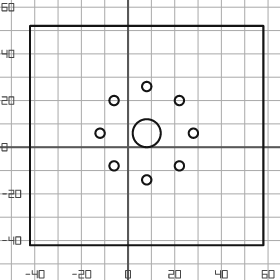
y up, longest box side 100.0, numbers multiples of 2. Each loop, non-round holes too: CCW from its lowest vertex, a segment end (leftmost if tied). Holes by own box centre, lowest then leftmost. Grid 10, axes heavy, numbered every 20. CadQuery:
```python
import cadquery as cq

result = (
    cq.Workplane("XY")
    .moveTo(-42.0, -42.0)
    .lineTo(58.0, -42.0)
    .lineTo(58.0, 52.0)
    .lineTo(-42.0, 52.0)
    .close()
    .moveTo(8.0, -14.0)
    .circle(2.0)
    .moveTo(-6.0, -8.0)
    .circle(2.0)
    .moveTo(22.0, -8.0)
    .circle(2.0)
    .moveTo(-12.0, 6.0)
    .circle(2.0)
    .moveTo(8.0, 6.0)
    .circle(6.0)
    .moveTo(28.0, 6.0)
    .circle(2.0)
    .moveTo(-6.0, 20.0)
    .circle(2.0)
    .moveTo(22.0, 20.0)
    .circle(2.0)
    .moveTo(8.0, 26.0)
    .circle(2.0)
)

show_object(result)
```